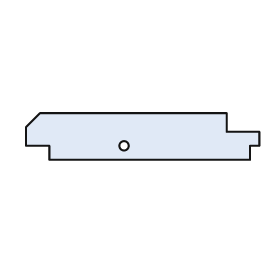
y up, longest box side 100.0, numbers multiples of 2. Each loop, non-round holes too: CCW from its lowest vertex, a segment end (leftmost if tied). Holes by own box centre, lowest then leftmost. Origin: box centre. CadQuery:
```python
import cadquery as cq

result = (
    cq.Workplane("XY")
    .moveTo(-40.0, -10.0)
    .lineTo(46.0, -10.0)
    .lineTo(46.0, -4.0)
    .lineTo(50.0, -4.0)
    .lineTo(50.0, 2.0)
    .lineTo(36.0, 2.0)
    .lineTo(36.0, 10.0)
    .lineTo(-44.0, 10.0)
    .lineTo(-50.0, 4.0)
    .lineTo(-50.0, -4.0)
    .lineTo(-40.0, -4.0)
    .close()
    .moveTo(-8.0, -4.0)
    .circle(2.0)
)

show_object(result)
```